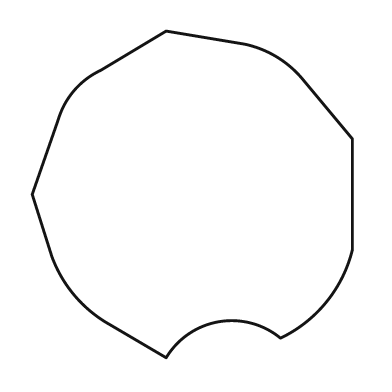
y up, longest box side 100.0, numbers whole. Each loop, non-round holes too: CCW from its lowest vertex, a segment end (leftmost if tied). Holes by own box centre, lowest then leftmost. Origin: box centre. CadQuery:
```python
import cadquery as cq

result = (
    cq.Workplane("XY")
    .moveTo(-8.0, -50.0)
    .threePointArc((8.0, -39.0), (27.0, -44.0))
    .threePointArc((41.0, -33.0), (49.0, -17.0))
    .lineTo(49.0, 17.0)
    .lineTo(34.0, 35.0)
    .threePointArc((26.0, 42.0), (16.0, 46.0))
    .lineTo(-8.0, 50.0)
    .lineTo(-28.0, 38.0)
    .threePointArc((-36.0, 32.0), (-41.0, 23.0))
    .lineTo(-49.0, 0.0)
    .lineTo(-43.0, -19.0)
    .threePointArc((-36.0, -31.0), (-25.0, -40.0))
    .close()
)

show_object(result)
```